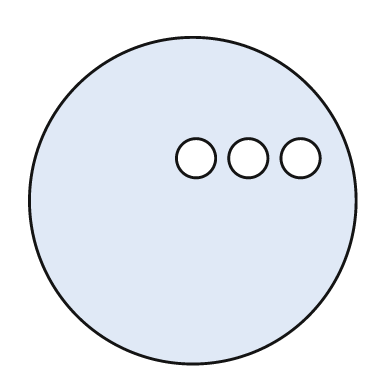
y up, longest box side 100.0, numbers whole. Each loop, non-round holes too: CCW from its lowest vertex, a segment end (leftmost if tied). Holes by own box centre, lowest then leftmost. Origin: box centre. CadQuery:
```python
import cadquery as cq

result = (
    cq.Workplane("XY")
    .moveTo(0.0, 0.0)
    .circle(50.0)
    .moveTo(1.0, 13.0)
    .circle(6.0)
    .moveTo(17.0, 13.0)
    .circle(6.0)
    .moveTo(33.0, 13.0)
    .circle(6.0)
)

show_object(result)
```